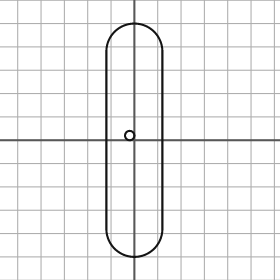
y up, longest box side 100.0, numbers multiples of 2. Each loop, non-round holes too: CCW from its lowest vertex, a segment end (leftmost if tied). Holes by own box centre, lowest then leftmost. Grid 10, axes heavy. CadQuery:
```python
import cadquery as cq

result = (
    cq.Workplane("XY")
    .moveTo(-12.0, -38.0)
    .threePointArc((0.0, -50.0), (12.0, -38.0))
    .lineTo(12.0, 38.0)
    .threePointArc((0.0, 50.0), (-12.0, 38.0))
    .close()
    .moveTo(-2.0, 2.0)
    .circle(2.0)
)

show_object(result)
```